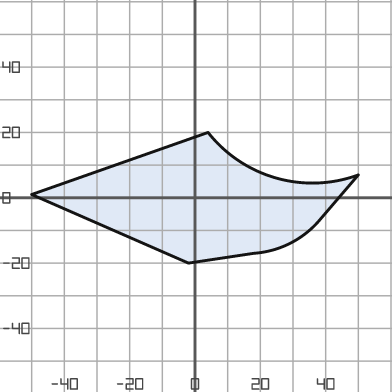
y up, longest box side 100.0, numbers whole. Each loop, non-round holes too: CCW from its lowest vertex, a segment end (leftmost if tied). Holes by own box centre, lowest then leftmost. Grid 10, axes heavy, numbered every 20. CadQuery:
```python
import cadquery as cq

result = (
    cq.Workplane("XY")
    .moveTo(-2.0, -20.0)
    .lineTo(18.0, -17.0)
    .threePointArc((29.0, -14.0), (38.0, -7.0))
    .lineTo(50.0, 7.0)
    .threePointArc((25.0, 6.0), (4.0, 20.0))
    .lineTo(-50.0, 1.0)
    .close()
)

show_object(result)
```